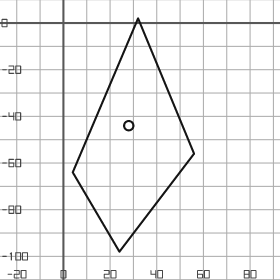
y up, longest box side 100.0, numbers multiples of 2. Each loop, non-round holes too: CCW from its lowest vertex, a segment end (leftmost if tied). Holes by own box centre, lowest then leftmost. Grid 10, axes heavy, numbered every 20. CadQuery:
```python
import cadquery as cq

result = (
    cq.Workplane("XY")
    .moveTo(24.0, -98.0)
    .lineTo(56.0, -56.0)
    .lineTo(32.0, 2.0)
    .lineTo(4.0, -64.0)
    .close()
    .moveTo(28.0, -44.0)
    .circle(2.0)
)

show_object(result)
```